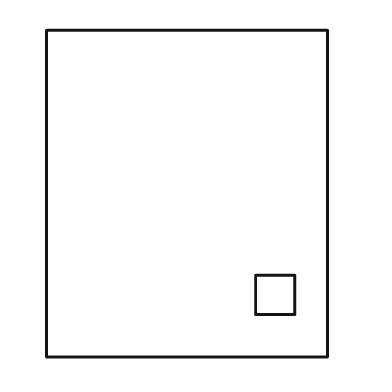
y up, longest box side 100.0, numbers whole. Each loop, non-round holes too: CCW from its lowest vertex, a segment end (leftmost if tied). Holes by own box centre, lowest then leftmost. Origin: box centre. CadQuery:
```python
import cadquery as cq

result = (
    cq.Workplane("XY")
    .moveTo(-43.0, -50.0)
    .lineTo(43.0, -50.0)
    .lineTo(43.0, 50.0)
    .lineTo(-43.0, 50.0)
    .close()
    .moveTo(21.0, -37.0)
    .lineTo(33.0, -37.0)
    .lineTo(33.0, -25.0)
    .lineTo(21.0, -25.0)
    .close()
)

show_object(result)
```